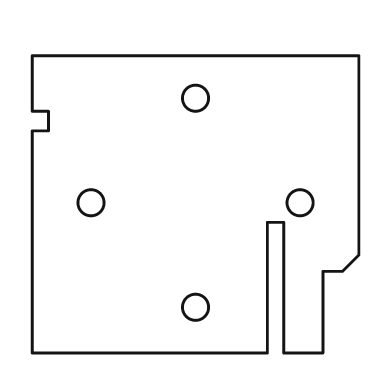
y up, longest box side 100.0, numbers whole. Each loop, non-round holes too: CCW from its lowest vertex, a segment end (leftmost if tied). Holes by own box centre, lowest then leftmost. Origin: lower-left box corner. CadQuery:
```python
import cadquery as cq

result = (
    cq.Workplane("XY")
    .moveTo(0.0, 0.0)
    .lineTo(72.0, 0.0)
    .lineTo(72.0, 40.0)
    .lineTo(77.0, 40.0)
    .lineTo(77.0, 0.0)
    .lineTo(89.0, 0.0)
    .lineTo(89.0, 25.0)
    .lineTo(95.0, 25.0)
    .lineTo(100.0, 30.0)
    .lineTo(100.0, 91.0)
    .lineTo(0.0, 91.0)
    .lineTo(0.0, 74.0)
    .lineTo(5.0, 74.0)
    .lineTo(5.0, 68.0)
    .lineTo(0.0, 68.0)
    .close()
    .moveTo(50.0, 14.0)
    .circle(4.0)
    .moveTo(18.0, 46.0)
    .circle(4.0)
    .moveTo(82.0, 46.0)
    .circle(4.0)
    .moveTo(50.0, 78.0)
    .circle(4.0)
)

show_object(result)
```